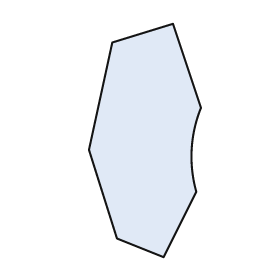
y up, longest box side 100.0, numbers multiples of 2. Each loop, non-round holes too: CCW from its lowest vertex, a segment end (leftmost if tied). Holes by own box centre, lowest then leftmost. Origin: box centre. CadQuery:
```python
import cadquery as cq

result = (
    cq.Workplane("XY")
    .moveTo(8.0, -50.0)
    .lineTo(22.0, -22.0)
    .threePointArc((20.0, -4.0), (24.0, 14.0))
    .lineTo(12.0, 50.0)
    .lineTo(-14.0, 42.0)
    .lineTo(-24.0, -4.0)
    .lineTo(-12.0, -42.0)
    .close()
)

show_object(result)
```